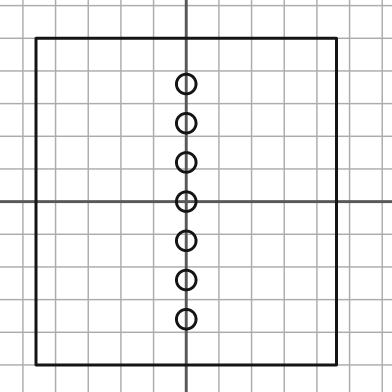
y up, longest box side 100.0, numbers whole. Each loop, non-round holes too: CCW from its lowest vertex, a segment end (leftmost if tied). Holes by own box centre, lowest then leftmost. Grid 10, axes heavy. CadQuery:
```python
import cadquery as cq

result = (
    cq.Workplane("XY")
    .moveTo(-46.0, -50.0)
    .lineTo(46.0, -50.0)
    .lineTo(46.0, 50.0)
    .lineTo(-46.0, 50.0)
    .close()
    .moveTo(0.0, -36.0)
    .circle(3.0)
    .moveTo(0.0, -24.0)
    .circle(3.0)
    .moveTo(0.0, -12.0)
    .circle(3.0)
    .moveTo(0.0, 0.0)
    .circle(3.0)
    .moveTo(0.0, 12.0)
    .circle(3.0)
    .moveTo(0.0, 24.0)
    .circle(3.0)
    .moveTo(0.0, 36.0)
    .circle(3.0)
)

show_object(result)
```